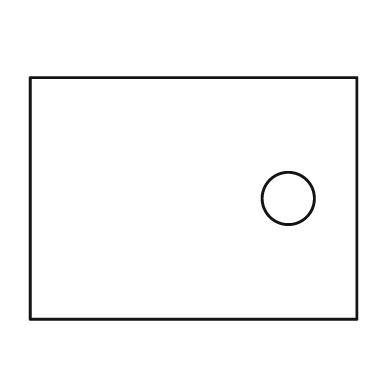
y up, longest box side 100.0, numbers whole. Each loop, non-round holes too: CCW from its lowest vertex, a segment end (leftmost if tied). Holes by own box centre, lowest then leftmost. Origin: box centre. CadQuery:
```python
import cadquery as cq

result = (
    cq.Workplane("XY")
    .moveTo(-50.0, -37.0)
    .lineTo(50.0, -37.0)
    .lineTo(50.0, 37.0)
    .lineTo(-50.0, 37.0)
    .close()
    .moveTo(29.0, 0.0)
    .circle(8.0)
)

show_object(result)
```